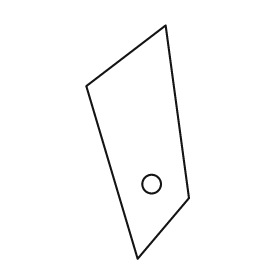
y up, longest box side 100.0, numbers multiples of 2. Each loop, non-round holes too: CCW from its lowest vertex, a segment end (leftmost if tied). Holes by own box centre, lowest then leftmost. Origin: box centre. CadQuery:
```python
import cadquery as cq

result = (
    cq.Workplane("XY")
    .moveTo(0.0, -50.0)
    .lineTo(22.0, -24.0)
    .lineTo(12.0, 50.0)
    .lineTo(-22.0, 24.0)
    .close()
    .moveTo(6.0, -18.0)
    .circle(4.0)
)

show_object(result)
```